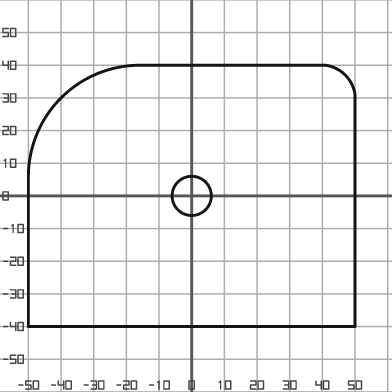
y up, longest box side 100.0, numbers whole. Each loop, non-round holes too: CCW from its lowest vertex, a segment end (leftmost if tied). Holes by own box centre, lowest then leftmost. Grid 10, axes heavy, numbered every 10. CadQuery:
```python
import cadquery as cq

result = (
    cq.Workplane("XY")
    .moveTo(-50.0, -40.0)
    .lineTo(50.0, -40.0)
    .lineTo(50.0, 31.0)
    .threePointArc((47.0, 37.0), (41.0, 40.0))
    .lineTo(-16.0, 40.0)
    .threePointArc((-40.0, 30.0), (-50.0, 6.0))
    .close()
    .moveTo(0.0, 0.0)
    .circle(6.0)
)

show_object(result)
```